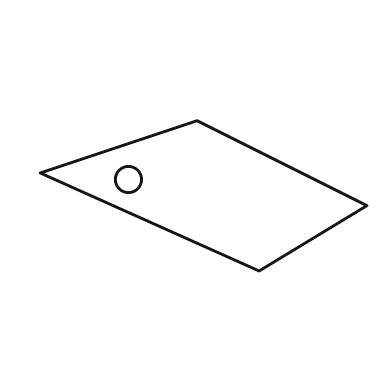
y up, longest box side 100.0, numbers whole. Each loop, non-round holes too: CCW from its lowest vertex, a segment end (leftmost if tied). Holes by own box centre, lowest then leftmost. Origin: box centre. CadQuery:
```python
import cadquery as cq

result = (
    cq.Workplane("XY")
    .moveTo(17.0, -23.0)
    .lineTo(50.0, -3.0)
    .lineTo(-2.0, 23.0)
    .lineTo(-50.0, 7.0)
    .close()
    .moveTo(-23.0, 5.0)
    .circle(4.0)
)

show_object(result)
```